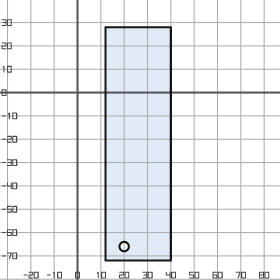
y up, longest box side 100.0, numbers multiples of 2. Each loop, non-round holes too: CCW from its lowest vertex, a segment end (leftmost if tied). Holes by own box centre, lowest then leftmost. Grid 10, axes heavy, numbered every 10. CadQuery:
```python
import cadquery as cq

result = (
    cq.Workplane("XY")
    .moveTo(12.0, -72.0)
    .lineTo(40.0, -72.0)
    .lineTo(40.0, 28.0)
    .lineTo(12.0, 28.0)
    .close()
    .moveTo(20.0, -66.0)
    .circle(2.0)
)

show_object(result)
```